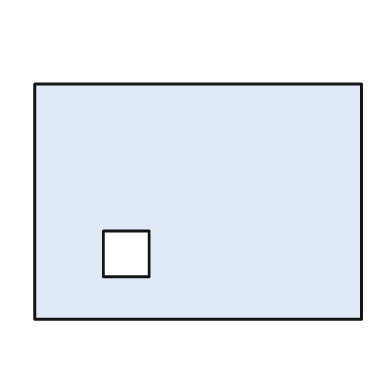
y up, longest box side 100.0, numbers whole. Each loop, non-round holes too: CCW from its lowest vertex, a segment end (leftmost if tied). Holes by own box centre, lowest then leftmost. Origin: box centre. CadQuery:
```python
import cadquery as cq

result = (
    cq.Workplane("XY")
    .moveTo(-50.0, -36.0)
    .lineTo(50.0, -36.0)
    .lineTo(50.0, 36.0)
    .lineTo(-50.0, 36.0)
    .close()
    .moveTo(-29.0, -23.0)
    .lineTo(-15.0, -23.0)
    .lineTo(-15.0, -9.0)
    .lineTo(-29.0, -9.0)
    .close()
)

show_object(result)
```